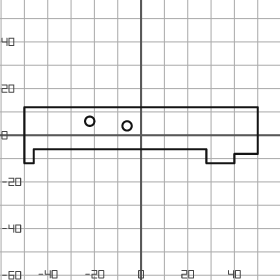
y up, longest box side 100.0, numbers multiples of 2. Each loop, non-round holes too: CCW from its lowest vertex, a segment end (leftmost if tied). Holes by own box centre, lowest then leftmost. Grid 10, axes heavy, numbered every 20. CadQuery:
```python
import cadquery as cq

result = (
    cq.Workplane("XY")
    .moveTo(-50.0, -12.0)
    .lineTo(-46.0, -12.0)
    .lineTo(-46.0, -6.0)
    .lineTo(28.0, -6.0)
    .lineTo(28.0, -12.0)
    .lineTo(40.0, -12.0)
    .lineTo(40.0, -8.0)
    .lineTo(50.0, -8.0)
    .lineTo(50.0, 12.0)
    .lineTo(-50.0, 12.0)
    .close()
    .moveTo(-6.0, 4.0)
    .circle(2.0)
    .moveTo(-22.0, 6.0)
    .circle(2.0)
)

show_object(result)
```